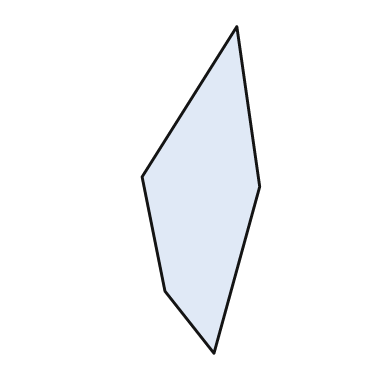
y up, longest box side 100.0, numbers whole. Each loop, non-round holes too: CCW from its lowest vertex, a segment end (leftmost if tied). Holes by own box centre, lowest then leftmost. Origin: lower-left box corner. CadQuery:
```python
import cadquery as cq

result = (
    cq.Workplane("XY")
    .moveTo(22.0, 0.0)
    .lineTo(36.0, 51.0)
    .lineTo(29.0, 100.0)
    .lineTo(0.0, 54.0)
    .lineTo(7.0, 19.0)
    .close()
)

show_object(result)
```